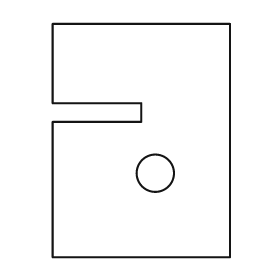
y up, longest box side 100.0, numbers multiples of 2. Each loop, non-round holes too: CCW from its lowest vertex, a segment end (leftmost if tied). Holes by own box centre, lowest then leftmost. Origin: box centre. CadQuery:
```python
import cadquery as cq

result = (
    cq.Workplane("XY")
    .moveTo(-38.0, -50.0)
    .lineTo(38.0, -50.0)
    .lineTo(38.0, 50.0)
    .lineTo(-38.0, 50.0)
    .lineTo(-38.0, 16.0)
    .lineTo(0.0, 16.0)
    .lineTo(0.0, 8.0)
    .lineTo(-38.0, 8.0)
    .close()
    .moveTo(6.0, -14.0)
    .circle(8.0)
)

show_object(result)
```